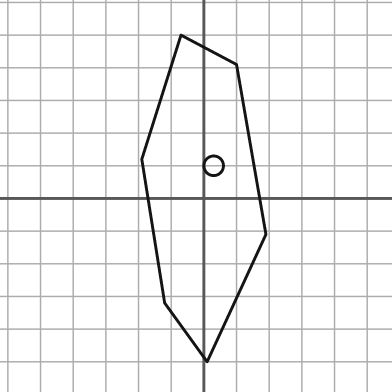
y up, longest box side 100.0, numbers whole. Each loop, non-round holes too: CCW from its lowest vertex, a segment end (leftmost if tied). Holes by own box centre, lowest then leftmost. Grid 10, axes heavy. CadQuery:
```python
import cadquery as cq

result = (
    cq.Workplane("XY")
    .moveTo(1.0, -50.0)
    .lineTo(19.0, -11.0)
    .lineTo(10.0, 41.0)
    .lineTo(-7.0, 50.0)
    .lineTo(-19.0, 12.0)
    .lineTo(-12.0, -32.0)
    .close()
    .moveTo(3.0, 10.0)
    .circle(3.0)
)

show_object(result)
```